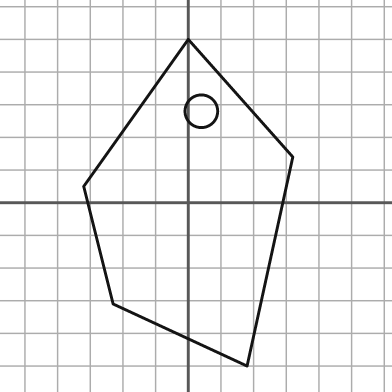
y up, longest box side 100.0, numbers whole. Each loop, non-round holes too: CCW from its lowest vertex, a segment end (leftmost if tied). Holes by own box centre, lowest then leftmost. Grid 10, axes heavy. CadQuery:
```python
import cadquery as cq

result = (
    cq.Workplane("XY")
    .moveTo(18.0, -50.0)
    .lineTo(32.0, 14.0)
    .lineTo(0.0, 50.0)
    .lineTo(-32.0, 5.0)
    .lineTo(-23.0, -31.0)
    .close()
    .moveTo(4.0, 28.0)
    .circle(5.0)
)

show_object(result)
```